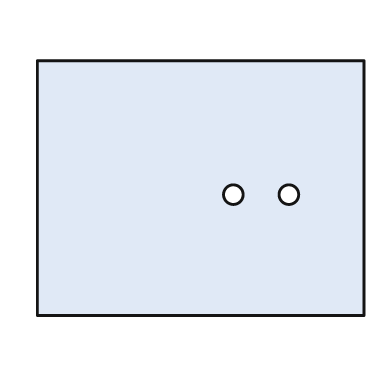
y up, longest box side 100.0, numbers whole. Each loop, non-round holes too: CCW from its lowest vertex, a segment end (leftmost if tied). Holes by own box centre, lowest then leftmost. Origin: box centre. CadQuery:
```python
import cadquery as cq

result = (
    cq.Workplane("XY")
    .moveTo(-50.0, -39.0)
    .lineTo(50.0, -39.0)
    .lineTo(50.0, 39.0)
    .lineTo(-50.0, 39.0)
    .close()
    .moveTo(10.0, -2.0)
    .circle(3.0)
    .moveTo(27.0, -2.0)
    .circle(3.0)
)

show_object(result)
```